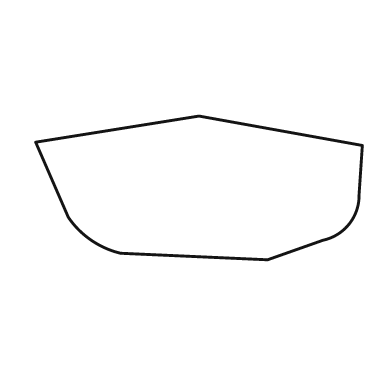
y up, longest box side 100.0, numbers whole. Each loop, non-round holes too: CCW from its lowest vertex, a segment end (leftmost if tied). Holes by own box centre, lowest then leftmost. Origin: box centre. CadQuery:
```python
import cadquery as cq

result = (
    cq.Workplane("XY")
    .moveTo(21.0, -22.0)
    .lineTo(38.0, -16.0)
    .threePointArc((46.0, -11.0), (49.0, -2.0))
    .lineTo(50.0, 13.0)
    .lineTo(0.0, 22.0)
    .lineTo(-50.0, 14.0)
    .lineTo(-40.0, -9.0)
    .threePointArc((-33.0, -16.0), (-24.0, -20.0))
    .close()
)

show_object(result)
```